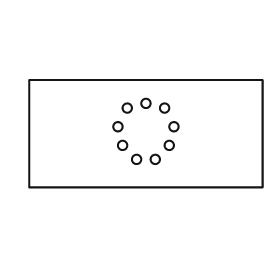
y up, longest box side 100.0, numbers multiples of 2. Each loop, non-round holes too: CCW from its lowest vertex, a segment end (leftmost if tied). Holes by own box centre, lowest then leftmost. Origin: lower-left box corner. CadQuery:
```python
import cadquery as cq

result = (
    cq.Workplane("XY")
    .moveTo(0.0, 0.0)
    .lineTo(100.0, 0.0)
    .lineTo(100.0, 46.0)
    .lineTo(0.0, 46.0)
    .close()
    .moveTo(46.0, 12.0)
    .circle(2.0)
    .moveTo(54.0, 12.0)
    .circle(2.0)
    .moveTo(40.0, 18.0)
    .circle(2.0)
    .moveTo(60.0, 18.0)
    .circle(2.0)
    .moveTo(38.0, 26.0)
    .circle(2.0)
    .moveTo(62.0, 26.0)
    .circle(2.0)
    .moveTo(42.0, 34.0)
    .circle(2.0)
    .moveTo(58.0, 34.0)
    .circle(2.0)
    .moveTo(50.0, 36.0)
    .circle(2.0)
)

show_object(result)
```